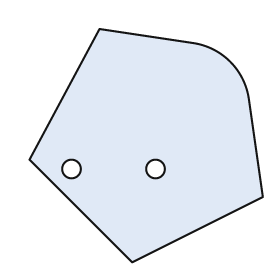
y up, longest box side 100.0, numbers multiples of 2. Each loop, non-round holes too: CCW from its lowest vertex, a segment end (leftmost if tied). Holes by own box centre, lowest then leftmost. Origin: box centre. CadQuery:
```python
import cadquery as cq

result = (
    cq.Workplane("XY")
    .moveTo(-6.0, -50.0)
    .lineTo(50.0, -22.0)
    .lineTo(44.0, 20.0)
    .threePointArc((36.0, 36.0), (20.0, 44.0))
    .lineTo(-20.0, 50.0)
    .lineTo(-50.0, -6.0)
    .close()
    .moveTo(-32.0, -10.0)
    .circle(4.0)
    .moveTo(4.0, -10.0)
    .circle(4.0)
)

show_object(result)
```